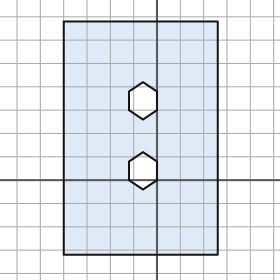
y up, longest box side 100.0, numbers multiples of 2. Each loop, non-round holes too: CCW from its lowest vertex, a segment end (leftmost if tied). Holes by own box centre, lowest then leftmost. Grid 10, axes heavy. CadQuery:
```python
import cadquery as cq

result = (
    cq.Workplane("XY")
    .moveTo(-40.0, -32.0)
    .lineTo(26.0, -32.0)
    .lineTo(26.0, 68.0)
    .lineTo(-40.0, 68.0)
    .close()
    .moveTo(-6.0, -4.0)
    .lineTo(0.0, 0.0)
    .lineTo(0.0, 8.0)
    .lineTo(-6.0, 12.0)
    .lineTo(-12.0, 8.0)
    .lineTo(-12.0, 0.0)
    .close()
    .moveTo(-6.0, 26.0)
    .lineTo(0.0, 30.0)
    .lineTo(0.0, 38.0)
    .lineTo(-6.0, 42.0)
    .lineTo(-12.0, 38.0)
    .lineTo(-12.0, 30.0)
    .close()
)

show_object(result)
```